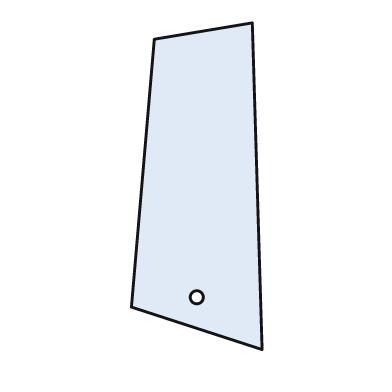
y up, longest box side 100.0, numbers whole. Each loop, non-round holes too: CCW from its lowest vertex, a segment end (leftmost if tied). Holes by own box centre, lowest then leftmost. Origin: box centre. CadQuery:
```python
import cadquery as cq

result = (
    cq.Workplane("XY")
    .moveTo(20.0, -50.0)
    .lineTo(17.0, 50.0)
    .lineTo(-13.0, 45.0)
    .lineTo(-20.0, -37.0)
    .close()
    .moveTo(0.0, -34.0)
    .circle(2.0)
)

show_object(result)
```